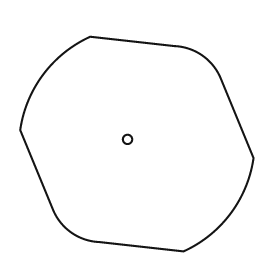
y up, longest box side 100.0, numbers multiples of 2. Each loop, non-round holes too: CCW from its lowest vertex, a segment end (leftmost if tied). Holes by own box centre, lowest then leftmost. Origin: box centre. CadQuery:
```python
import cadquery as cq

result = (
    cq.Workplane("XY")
    .moveTo(20.0, -46.0)
    .threePointArc((40.0, -30.0), (50.0, -6.0))
    .lineTo(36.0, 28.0)
    .threePointArc((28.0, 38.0), (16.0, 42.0))
    .lineTo(-20.0, 46.0)
    .threePointArc((-40.0, 30.0), (-50.0, 6.0))
    .lineTo(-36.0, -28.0)
    .threePointArc((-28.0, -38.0), (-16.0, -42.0))
    .close()
    .moveTo(-4.0, 2.0)
    .circle(2.0)
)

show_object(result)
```